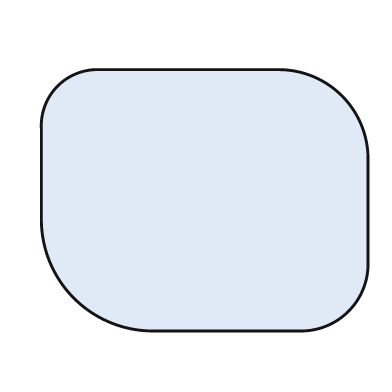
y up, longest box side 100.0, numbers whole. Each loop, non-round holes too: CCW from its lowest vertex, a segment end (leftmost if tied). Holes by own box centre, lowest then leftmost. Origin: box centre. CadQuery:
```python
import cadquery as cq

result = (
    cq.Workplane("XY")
    .moveTo(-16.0, -40.0)
    .lineTo(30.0, -40.0)
    .threePointArc((44.0, -34.0), (50.0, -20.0))
    .lineTo(50.0, 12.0)
    .threePointArc((42.0, 32.0), (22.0, 40.0))
    .lineTo(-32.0, 40.0)
    .threePointArc((-45.0, 35.0), (-50.0, 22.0))
    .lineTo(-50.0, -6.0)
    .threePointArc((-40.0, -30.0), (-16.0, -40.0))
    .close()
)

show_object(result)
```